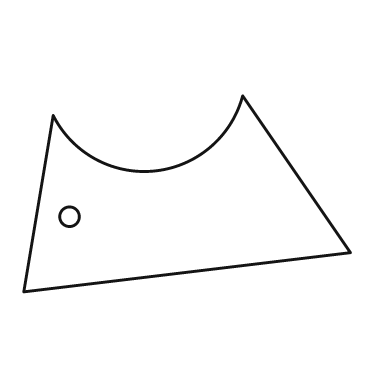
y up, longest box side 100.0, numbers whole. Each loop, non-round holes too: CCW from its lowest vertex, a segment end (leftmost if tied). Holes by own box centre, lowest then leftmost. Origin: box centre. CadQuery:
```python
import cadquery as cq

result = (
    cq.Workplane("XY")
    .moveTo(-50.0, -30.0)
    .lineTo(50.0, -18.0)
    .lineTo(17.0, 30.0)
    .threePointArc((-10.0, 7.0), (-41.0, 24.0))
    .close()
    .moveTo(-36.0, -7.0)
    .circle(3.0)
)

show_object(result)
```